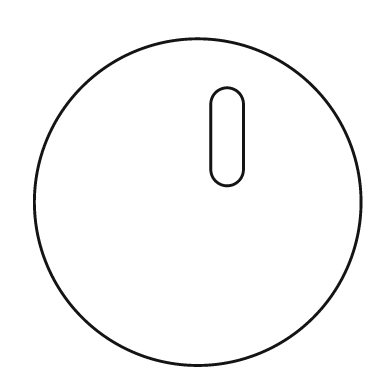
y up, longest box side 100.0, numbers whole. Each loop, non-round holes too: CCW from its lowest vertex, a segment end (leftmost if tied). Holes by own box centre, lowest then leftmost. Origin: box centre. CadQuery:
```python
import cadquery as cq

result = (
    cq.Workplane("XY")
    .moveTo(0.0, 0.0)
    .circle(50.0)
    .moveTo(4.0, 10.0)
    .threePointArc((9.0, 5.0), (14.0, 10.0))
    .lineTo(14.0, 30.0)
    .threePointArc((9.0, 35.0), (4.0, 30.0))
    .close()
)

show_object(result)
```